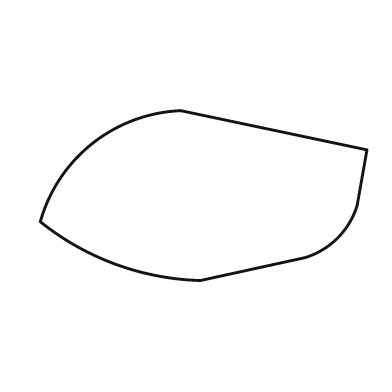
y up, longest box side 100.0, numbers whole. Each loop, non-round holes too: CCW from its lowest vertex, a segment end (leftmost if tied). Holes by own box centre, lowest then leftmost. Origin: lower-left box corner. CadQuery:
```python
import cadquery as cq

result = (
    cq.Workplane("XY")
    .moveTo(49.0, 0.0)
    .lineTo(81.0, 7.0)
    .threePointArc((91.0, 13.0), (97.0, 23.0))
    .lineTo(100.0, 40.0)
    .lineTo(43.0, 52.0)
    .threePointArc((16.0, 42.0), (0.0, 18.0))
    .threePointArc((23.0, 5.0), (49.0, 0.0))
    .close()
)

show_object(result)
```